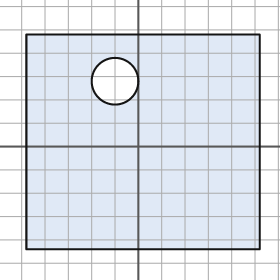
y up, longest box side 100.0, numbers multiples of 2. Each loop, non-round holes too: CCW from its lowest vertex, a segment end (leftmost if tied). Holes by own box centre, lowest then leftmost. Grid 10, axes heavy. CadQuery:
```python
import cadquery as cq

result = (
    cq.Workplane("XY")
    .moveTo(-48.0, -44.0)
    .lineTo(52.0, -44.0)
    .lineTo(52.0, 48.0)
    .lineTo(-48.0, 48.0)
    .close()
    .moveTo(-10.0, 28.0)
    .circle(10.0)
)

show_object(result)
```